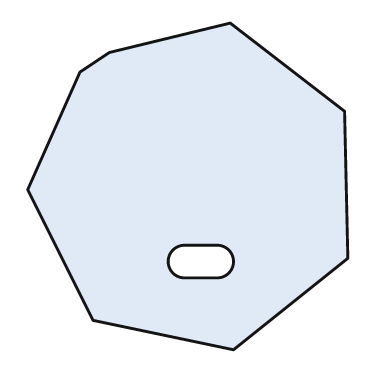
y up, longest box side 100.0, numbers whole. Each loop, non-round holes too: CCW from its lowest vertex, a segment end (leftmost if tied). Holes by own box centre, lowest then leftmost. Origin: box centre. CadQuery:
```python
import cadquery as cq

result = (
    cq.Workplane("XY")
    .moveTo(14.0, -50.0)
    .lineTo(49.0, -22.0)
    .lineTo(48.0, 23.0)
    .lineTo(13.0, 50.0)
    .lineTo(-24.0, 41.0)
    .lineTo(-33.0, 35.0)
    .lineTo(-49.0, -1.0)
    .lineTo(-29.0, -41.0)
    .close()
    .moveTo(-1.0, -28.0)
    .lineTo(9.0, -28.0)
    .threePointArc((14.0, -23.0), (9.0, -18.0))
    .lineTo(-1.0, -18.0)
    .threePointArc((-6.0, -23.0), (-1.0, -28.0))
    .close()
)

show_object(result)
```